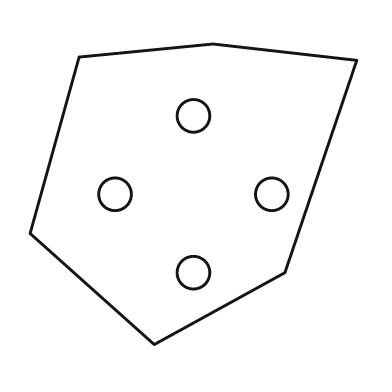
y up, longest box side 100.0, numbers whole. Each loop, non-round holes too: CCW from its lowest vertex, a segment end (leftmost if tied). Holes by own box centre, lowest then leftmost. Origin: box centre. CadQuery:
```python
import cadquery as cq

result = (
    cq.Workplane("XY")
    .moveTo(-12.0, -46.0)
    .lineTo(28.0, -24.0)
    .lineTo(50.0, 41.0)
    .lineTo(6.0, 46.0)
    .lineTo(-35.0, 42.0)
    .lineTo(-50.0, -12.0)
    .close()
    .moveTo(0.0, -24.0)
    .circle(5.0)
    .moveTo(-24.0, 0.0)
    .circle(5.0)
    .moveTo(24.0, 0.0)
    .circle(5.0)
    .moveTo(0.0, 24.0)
    .circle(5.0)
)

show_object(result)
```